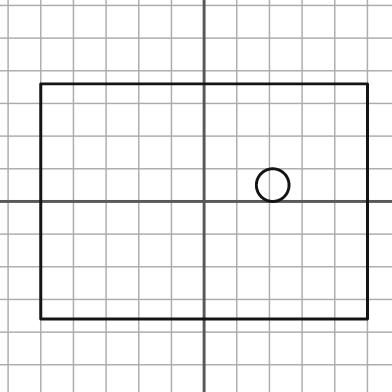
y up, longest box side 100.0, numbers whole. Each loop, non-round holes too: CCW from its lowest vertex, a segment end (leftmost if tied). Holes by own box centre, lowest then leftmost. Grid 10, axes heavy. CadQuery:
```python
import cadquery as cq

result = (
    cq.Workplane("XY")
    .moveTo(-50.0, -36.0)
    .lineTo(50.0, -36.0)
    .lineTo(50.0, 36.0)
    .lineTo(-50.0, 36.0)
    .close()
    .moveTo(21.0, 5.0)
    .circle(5.0)
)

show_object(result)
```